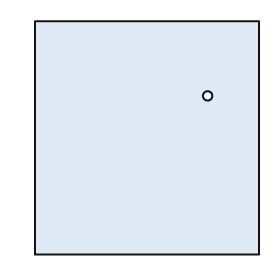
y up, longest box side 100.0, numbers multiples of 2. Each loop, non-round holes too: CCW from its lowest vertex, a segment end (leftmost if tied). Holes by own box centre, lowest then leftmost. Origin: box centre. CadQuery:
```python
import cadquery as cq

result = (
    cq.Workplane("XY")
    .moveTo(-48.0, -50.0)
    .lineTo(48.0, -50.0)
    .lineTo(48.0, 50.0)
    .lineTo(-48.0, 50.0)
    .close()
    .moveTo(26.0, 18.0)
    .circle(2.0)
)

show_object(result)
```